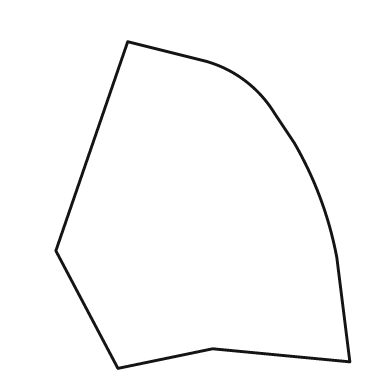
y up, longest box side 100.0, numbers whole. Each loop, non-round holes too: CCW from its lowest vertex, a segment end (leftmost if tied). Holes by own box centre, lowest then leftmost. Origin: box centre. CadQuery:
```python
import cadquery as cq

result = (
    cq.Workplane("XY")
    .moveTo(-26.0, -50.0)
    .lineTo(3.0, -44.0)
    .lineTo(45.0, -48.0)
    .lineTo(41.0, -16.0)
    .threePointArc((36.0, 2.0), (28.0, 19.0))
    .lineTo(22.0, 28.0)
    .threePointArc((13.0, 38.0), (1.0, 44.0))
    .lineTo(-23.0, 50.0)
    .lineTo(-45.0, -14.0)
    .close()
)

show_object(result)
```